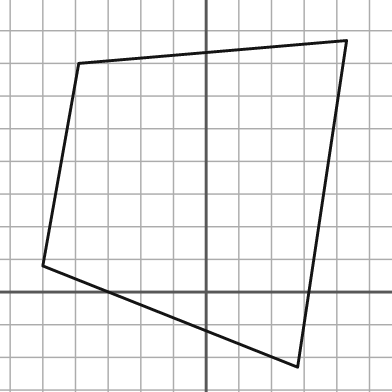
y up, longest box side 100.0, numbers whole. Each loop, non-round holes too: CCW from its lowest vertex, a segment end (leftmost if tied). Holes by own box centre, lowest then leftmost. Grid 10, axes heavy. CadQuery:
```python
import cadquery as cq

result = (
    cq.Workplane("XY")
    .moveTo(28.0, -23.0)
    .lineTo(43.0, 77.0)
    .lineTo(-39.0, 70.0)
    .lineTo(-50.0, 8.0)
    .close()
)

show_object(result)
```